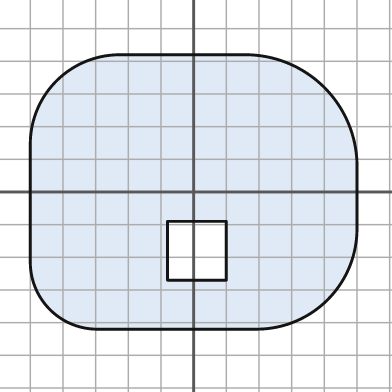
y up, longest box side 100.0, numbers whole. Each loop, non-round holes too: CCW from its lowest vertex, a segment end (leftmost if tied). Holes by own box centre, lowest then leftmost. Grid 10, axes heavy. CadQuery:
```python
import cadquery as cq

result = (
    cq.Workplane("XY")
    .moveTo(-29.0, -42.0)
    .lineTo(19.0, -42.0)
    .threePointArc((41.0, -33.0), (50.0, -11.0))
    .lineTo(50.0, 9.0)
    .threePointArc((40.0, 32.0), (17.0, 42.0))
    .lineTo(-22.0, 42.0)
    .threePointArc((-42.0, 34.0), (-50.0, 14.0))
    .lineTo(-50.0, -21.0)
    .threePointArc((-44.0, -36.0), (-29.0, -42.0))
    .close()
    .moveTo(-8.0, -27.0)
    .lineTo(10.0, -27.0)
    .lineTo(10.0, -9.0)
    .lineTo(-8.0, -9.0)
    .close()
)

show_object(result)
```